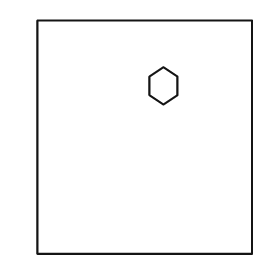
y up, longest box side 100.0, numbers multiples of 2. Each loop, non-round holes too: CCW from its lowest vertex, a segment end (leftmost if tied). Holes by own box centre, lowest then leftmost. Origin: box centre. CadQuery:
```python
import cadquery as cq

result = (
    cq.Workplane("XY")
    .moveTo(-46.0, -50.0)
    .lineTo(46.0, -50.0)
    .lineTo(46.0, 50.0)
    .lineTo(-46.0, 50.0)
    .close()
    .moveTo(8.0, 14.0)
    .lineTo(14.0, 18.0)
    .lineTo(14.0, 26.0)
    .lineTo(8.0, 30.0)
    .lineTo(2.0, 26.0)
    .lineTo(2.0, 18.0)
    .close()
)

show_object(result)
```